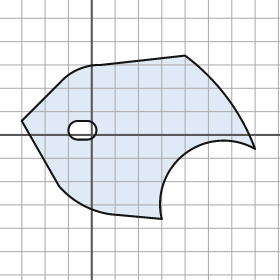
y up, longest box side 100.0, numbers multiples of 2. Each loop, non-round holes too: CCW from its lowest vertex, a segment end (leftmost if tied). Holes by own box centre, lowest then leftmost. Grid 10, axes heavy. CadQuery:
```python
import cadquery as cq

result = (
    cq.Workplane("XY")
    .moveTo(30.0, -36.0)
    .threePointArc((40.0, -8.0), (70.0, -6.0))
    .threePointArc((58.0, 16.0), (40.0, 34.0))
    .lineTo(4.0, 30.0)
    .threePointArc((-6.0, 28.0), (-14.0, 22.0))
    .lineTo(-30.0, 6.0)
    .lineTo(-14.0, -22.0)
    .threePointArc((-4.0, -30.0), (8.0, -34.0))
    .close()
    .moveTo(-6.0, -2.0)
    .lineTo(-2.0, -2.0)
    .threePointArc((2.0, 2.0), (-2.0, 6.0))
    .lineTo(-6.0, 6.0)
    .threePointArc((-10.0, 2.0), (-6.0, -2.0))
    .close()
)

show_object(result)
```